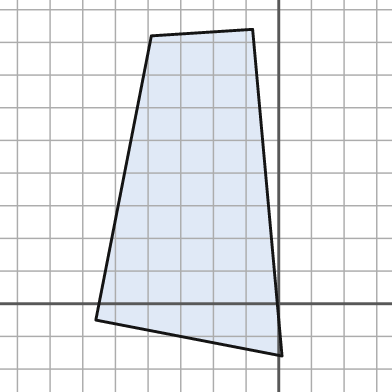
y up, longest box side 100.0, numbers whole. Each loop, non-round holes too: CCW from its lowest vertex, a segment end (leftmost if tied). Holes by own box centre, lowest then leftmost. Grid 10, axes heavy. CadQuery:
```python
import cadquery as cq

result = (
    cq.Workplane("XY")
    .moveTo(1.0, -16.0)
    .lineTo(-8.0, 84.0)
    .lineTo(-39.0, 82.0)
    .lineTo(-56.0, -5.0)
    .close()
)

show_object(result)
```